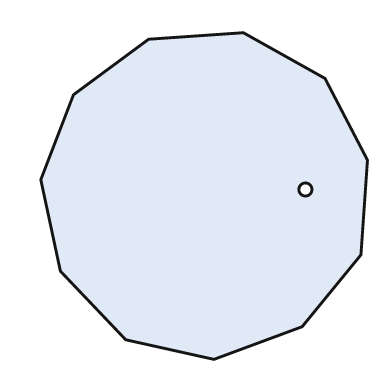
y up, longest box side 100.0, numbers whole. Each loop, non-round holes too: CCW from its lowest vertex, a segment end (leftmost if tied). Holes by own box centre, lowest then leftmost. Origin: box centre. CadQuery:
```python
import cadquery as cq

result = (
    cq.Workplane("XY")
    .moveTo(3.0, -50.0)
    .lineTo(30.0, -40.0)
    .lineTo(48.0, -18.0)
    .lineTo(50.0, 11.0)
    .lineTo(37.0, 36.0)
    .lineTo(12.0, 50.0)
    .lineTo(-17.0, 48.0)
    .lineTo(-40.0, 31.0)
    .lineTo(-50.0, 5.0)
    .lineTo(-44.0, -23.0)
    .lineTo(-24.0, -44.0)
    .close()
    .moveTo(31.0, 2.0)
    .circle(2.0)
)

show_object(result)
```